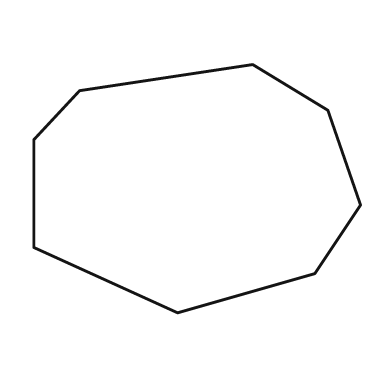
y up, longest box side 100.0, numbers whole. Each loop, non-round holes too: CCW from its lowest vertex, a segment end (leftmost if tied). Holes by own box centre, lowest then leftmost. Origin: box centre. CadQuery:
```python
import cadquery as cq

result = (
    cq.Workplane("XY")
    .moveTo(-6.0, -38.0)
    .lineTo(36.0, -26.0)
    .lineTo(50.0, -5.0)
    .lineTo(40.0, 24.0)
    .lineTo(17.0, 38.0)
    .lineTo(-36.0, 30.0)
    .lineTo(-50.0, 15.0)
    .lineTo(-50.0, -18.0)
    .close()
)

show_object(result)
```